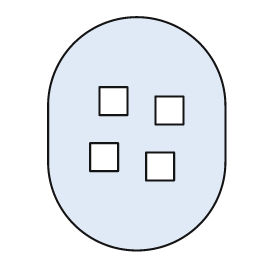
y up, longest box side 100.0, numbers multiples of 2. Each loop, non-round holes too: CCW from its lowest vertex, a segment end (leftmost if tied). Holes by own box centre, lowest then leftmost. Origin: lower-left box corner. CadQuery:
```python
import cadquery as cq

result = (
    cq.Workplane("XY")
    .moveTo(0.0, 38.0)
    .threePointArc((38.0, 0.0), (76.0, 38.0))
    .lineTo(76.0, 62.0)
    .threePointArc((38.0, 100.0), (0.0, 62.0))
    .close()
    .moveTo(42.0, 30.0)
    .lineTo(54.0, 30.0)
    .lineTo(54.0, 42.0)
    .lineTo(42.0, 42.0)
    .close()
    .moveTo(18.0, 34.0)
    .lineTo(30.0, 34.0)
    .lineTo(30.0, 46.0)
    .lineTo(18.0, 46.0)
    .close()
    .moveTo(46.0, 54.0)
    .lineTo(58.0, 54.0)
    .lineTo(58.0, 66.0)
    .lineTo(46.0, 66.0)
    .close()
    .moveTo(22.0, 58.0)
    .lineTo(34.0, 58.0)
    .lineTo(34.0, 70.0)
    .lineTo(22.0, 70.0)
    .close()
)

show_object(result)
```